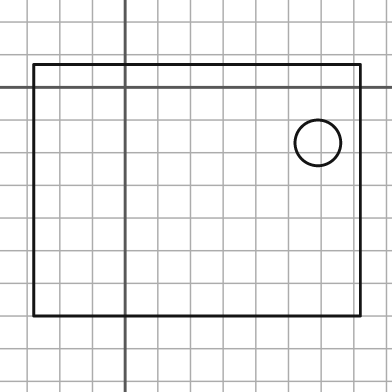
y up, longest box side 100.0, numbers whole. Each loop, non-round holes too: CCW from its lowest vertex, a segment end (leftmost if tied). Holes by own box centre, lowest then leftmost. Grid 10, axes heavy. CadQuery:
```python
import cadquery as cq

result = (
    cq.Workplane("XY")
    .moveTo(-28.0, -70.0)
    .lineTo(72.0, -70.0)
    .lineTo(72.0, 7.0)
    .lineTo(-28.0, 7.0)
    .close()
    .moveTo(59.0, -17.0)
    .circle(7.0)
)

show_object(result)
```